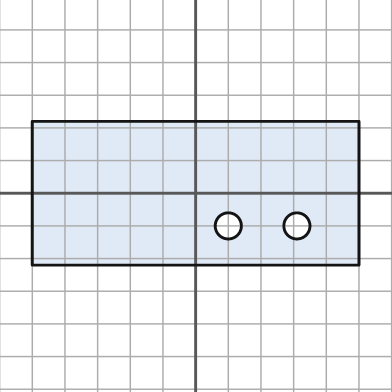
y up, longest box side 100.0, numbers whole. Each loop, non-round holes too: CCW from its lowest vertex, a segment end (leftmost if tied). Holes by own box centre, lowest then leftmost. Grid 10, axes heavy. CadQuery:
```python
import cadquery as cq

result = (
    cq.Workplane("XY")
    .moveTo(-50.0, -22.0)
    .lineTo(50.0, -22.0)
    .lineTo(50.0, 22.0)
    .lineTo(-50.0, 22.0)
    .close()
    .moveTo(10.0, -10.0)
    .circle(4.0)
    .moveTo(31.0, -10.0)
    .circle(4.0)
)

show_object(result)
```